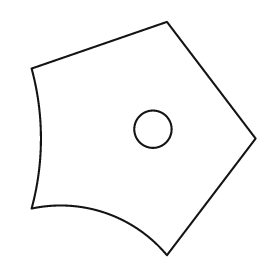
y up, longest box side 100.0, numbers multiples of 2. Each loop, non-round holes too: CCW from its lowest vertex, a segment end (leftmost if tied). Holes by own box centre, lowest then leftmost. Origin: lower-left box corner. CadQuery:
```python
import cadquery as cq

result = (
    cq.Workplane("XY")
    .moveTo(58.0, 0.0)
    .lineTo(96.0, 50.0)
    .lineTo(58.0, 100.0)
    .lineTo(0.0, 80.0)
    .threePointArc((4.0, 50.0), (0.0, 20.0))
    .threePointArc((32.0, 18.0), (58.0, 0.0))
    .close()
    .moveTo(52.0, 54.0)
    .circle(8.0)
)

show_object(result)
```